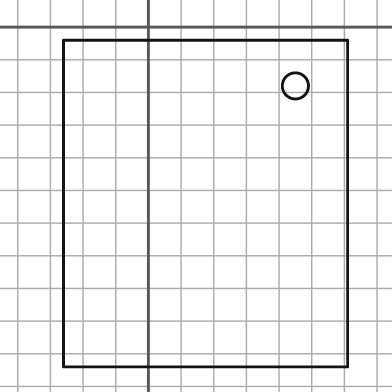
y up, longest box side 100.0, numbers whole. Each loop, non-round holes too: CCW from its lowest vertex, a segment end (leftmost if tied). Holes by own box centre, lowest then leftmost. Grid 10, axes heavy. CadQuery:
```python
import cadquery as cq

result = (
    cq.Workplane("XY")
    .moveTo(-26.0, -104.0)
    .lineTo(61.0, -104.0)
    .lineTo(61.0, -4.0)
    .lineTo(-26.0, -4.0)
    .close()
    .moveTo(45.0, -18.0)
    .circle(4.0)
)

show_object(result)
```